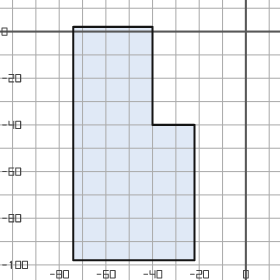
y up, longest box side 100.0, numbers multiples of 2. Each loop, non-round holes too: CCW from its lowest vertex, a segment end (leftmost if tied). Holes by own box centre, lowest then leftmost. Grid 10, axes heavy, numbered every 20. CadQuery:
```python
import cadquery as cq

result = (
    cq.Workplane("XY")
    .moveTo(-74.0, -98.0)
    .lineTo(-22.0, -98.0)
    .lineTo(-22.0, -40.0)
    .lineTo(-40.0, -40.0)
    .lineTo(-40.0, 2.0)
    .lineTo(-74.0, 2.0)
    .close()
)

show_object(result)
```